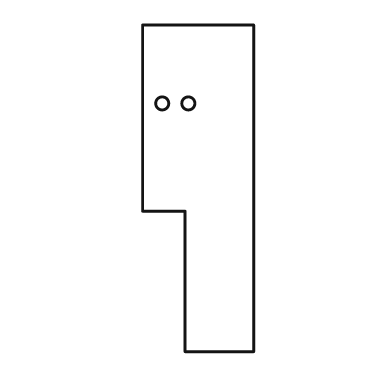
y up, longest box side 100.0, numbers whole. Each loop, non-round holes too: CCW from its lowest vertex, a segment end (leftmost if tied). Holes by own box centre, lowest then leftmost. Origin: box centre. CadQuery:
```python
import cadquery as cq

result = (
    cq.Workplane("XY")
    .moveTo(-4.0, -50.0)
    .lineTo(17.0, -50.0)
    .lineTo(17.0, 50.0)
    .lineTo(-17.0, 50.0)
    .lineTo(-17.0, -7.0)
    .lineTo(-4.0, -7.0)
    .close()
    .moveTo(-11.0, 26.0)
    .circle(2.0)
    .moveTo(-3.0, 26.0)
    .circle(2.0)
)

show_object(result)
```